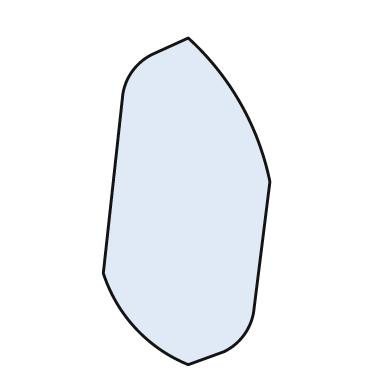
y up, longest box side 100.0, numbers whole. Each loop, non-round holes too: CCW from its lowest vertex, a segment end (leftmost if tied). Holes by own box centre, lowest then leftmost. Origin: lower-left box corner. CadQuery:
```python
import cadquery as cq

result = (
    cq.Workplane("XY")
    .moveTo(26.0, 0.0)
    .lineTo(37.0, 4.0)
    .threePointArc((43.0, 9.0), (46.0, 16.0))
    .lineTo(51.0, 56.0)
    .threePointArc((42.0, 80.0), (26.0, 100.0))
    .lineTo(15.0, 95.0)
    .threePointArc((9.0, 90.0), (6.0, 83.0))
    .lineTo(0.0, 28.0)
    .threePointArc((10.0, 11.0), (26.0, 0.0))
    .close()
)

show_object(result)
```